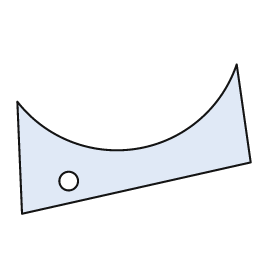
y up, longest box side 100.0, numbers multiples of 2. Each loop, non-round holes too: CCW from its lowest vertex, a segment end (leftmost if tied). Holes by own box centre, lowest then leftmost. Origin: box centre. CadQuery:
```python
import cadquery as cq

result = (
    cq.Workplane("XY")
    .moveTo(-48.0, -32.0)
    .lineTo(50.0, -10.0)
    .lineTo(44.0, 32.0)
    .threePointArc((2.0, -4.0), (-50.0, 16.0))
    .close()
    .moveTo(-28.0, -18.0)
    .circle(4.0)
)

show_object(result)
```